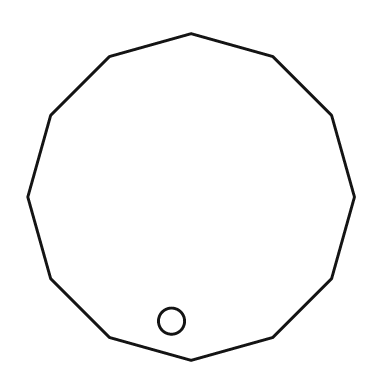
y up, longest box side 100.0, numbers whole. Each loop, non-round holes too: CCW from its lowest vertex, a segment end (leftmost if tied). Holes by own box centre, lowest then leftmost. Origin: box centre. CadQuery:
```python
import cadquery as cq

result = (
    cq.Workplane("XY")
    .moveTo(0.0, -50.0)
    .lineTo(25.0, -43.0)
    .lineTo(43.0, -25.0)
    .lineTo(50.0, 0.0)
    .lineTo(43.0, 25.0)
    .lineTo(25.0, 43.0)
    .lineTo(0.0, 50.0)
    .lineTo(-25.0, 43.0)
    .lineTo(-43.0, 25.0)
    .lineTo(-50.0, 0.0)
    .lineTo(-43.0, -25.0)
    .lineTo(-25.0, -43.0)
    .close()
    .moveTo(-6.0, -38.0)
    .circle(4.0)
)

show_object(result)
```